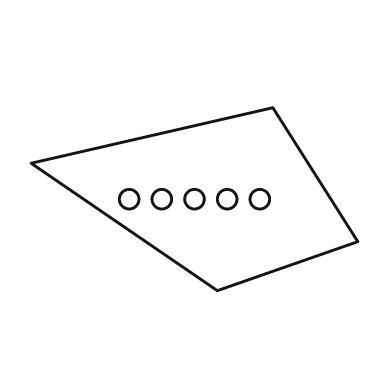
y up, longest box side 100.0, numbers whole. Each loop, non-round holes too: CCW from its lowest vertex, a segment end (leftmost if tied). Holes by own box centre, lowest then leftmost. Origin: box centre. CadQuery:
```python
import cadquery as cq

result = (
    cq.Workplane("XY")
    .moveTo(7.0, -28.0)
    .lineTo(50.0, -13.0)
    .lineTo(24.0, 28.0)
    .lineTo(-50.0, 11.0)
    .close()
    .moveTo(-20.0, 0.0)
    .circle(3.0)
    .moveTo(-10.0, 0.0)
    .circle(3.0)
    .moveTo(0.0, 0.0)
    .circle(3.0)
    .moveTo(10.0, 0.0)
    .circle(3.0)
    .moveTo(20.0, 0.0)
    .circle(3.0)
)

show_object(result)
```